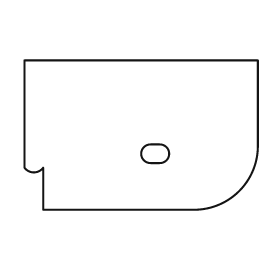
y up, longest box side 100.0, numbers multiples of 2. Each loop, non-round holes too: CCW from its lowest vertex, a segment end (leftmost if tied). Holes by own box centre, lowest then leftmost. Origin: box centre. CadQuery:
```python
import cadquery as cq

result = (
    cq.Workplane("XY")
    .moveTo(-42.0, -32.0)
    .lineTo(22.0, -32.0)
    .threePointArc((42.0, -24.0), (50.0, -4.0))
    .lineTo(50.0, 32.0)
    .lineTo(-50.0, 32.0)
    .lineTo(-50.0, -14.0)
    .threePointArc((-46.0, -16.0), (-42.0, -14.0))
    .close()
    .moveTo(4.0, -12.0)
    .lineTo(8.0, -12.0)
    .threePointArc((12.0, -8.0), (8.0, -4.0))
    .lineTo(4.0, -4.0)
    .threePointArc((0.0, -8.0), (4.0, -12.0))
    .close()
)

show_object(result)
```